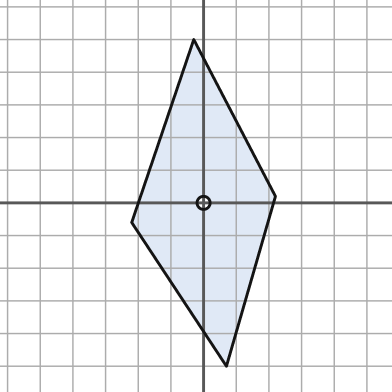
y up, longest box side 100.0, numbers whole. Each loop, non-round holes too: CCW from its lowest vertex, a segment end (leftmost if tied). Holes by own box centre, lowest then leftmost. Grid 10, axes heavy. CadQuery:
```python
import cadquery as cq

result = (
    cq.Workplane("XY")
    .moveTo(7.0, -50.0)
    .lineTo(22.0, 2.0)
    .lineTo(-3.0, 50.0)
    .lineTo(-22.0, -6.0)
    .close()
    .moveTo(0.0, 0.0)
    .circle(2.0)
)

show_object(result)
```